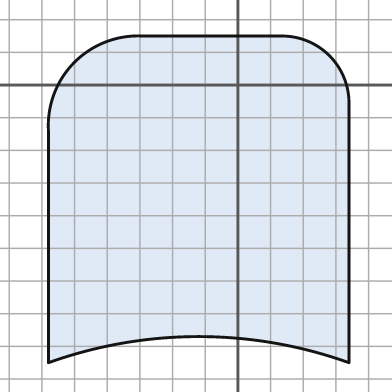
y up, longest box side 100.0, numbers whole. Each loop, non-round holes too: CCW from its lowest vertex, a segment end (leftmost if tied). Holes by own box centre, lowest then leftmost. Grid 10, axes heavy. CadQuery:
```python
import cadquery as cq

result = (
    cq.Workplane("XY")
    .moveTo(-58.0, -85.0)
    .threePointArc((-12.0, -77.0), (34.0, -85.0))
    .lineTo(34.0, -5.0)
    .threePointArc((28.0, 9.0), (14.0, 15.0))
    .lineTo(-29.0, 15.0)
    .threePointArc((-50.0, 7.0), (-58.0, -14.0))
    .close()
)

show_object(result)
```